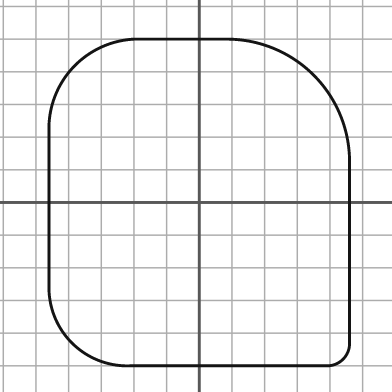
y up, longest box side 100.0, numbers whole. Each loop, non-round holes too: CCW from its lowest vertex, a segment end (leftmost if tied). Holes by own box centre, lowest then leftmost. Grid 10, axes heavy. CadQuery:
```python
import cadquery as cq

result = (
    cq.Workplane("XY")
    .moveTo(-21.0, -50.0)
    .lineTo(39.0, -50.0)
    .threePointArc((44.0, -48.0), (46.0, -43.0))
    .lineTo(46.0, 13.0)
    .threePointArc((35.0, 39.0), (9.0, 50.0))
    .lineTo(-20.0, 50.0)
    .threePointArc((-38.0, 42.0), (-46.0, 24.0))
    .lineTo(-46.0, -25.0)
    .threePointArc((-39.0, -43.0), (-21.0, -50.0))
    .close()
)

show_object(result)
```